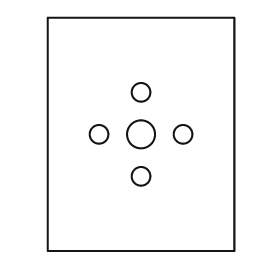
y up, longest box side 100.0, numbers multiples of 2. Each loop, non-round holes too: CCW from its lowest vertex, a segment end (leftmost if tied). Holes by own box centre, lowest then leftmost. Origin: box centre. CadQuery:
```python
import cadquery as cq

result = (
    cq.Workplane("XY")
    .moveTo(-40.0, -50.0)
    .lineTo(40.0, -50.0)
    .lineTo(40.0, 50.0)
    .lineTo(-40.0, 50.0)
    .close()
    .moveTo(0.0, -18.0)
    .circle(4.0)
    .moveTo(-18.0, 0.0)
    .circle(4.0)
    .moveTo(0.0, 0.0)
    .circle(6.0)
    .moveTo(18.0, 0.0)
    .circle(4.0)
    .moveTo(0.0, 18.0)
    .circle(4.0)
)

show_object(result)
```